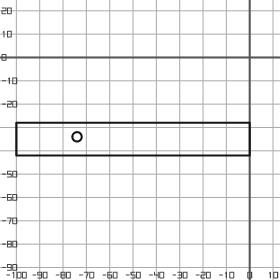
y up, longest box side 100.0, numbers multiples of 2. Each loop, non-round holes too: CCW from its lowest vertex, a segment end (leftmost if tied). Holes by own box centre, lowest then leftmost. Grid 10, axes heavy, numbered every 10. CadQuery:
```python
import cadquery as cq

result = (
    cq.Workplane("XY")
    .moveTo(-100.0, -42.0)
    .lineTo(0.0, -42.0)
    .lineTo(0.0, -28.0)
    .lineTo(-100.0, -28.0)
    .close()
    .moveTo(-74.0, -34.0)
    .circle(2.0)
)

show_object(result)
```